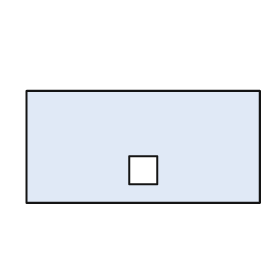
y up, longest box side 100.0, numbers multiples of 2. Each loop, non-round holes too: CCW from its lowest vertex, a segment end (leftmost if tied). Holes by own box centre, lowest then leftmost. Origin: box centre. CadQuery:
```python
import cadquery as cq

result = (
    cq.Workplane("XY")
    .moveTo(-50.0, -24.0)
    .lineTo(50.0, -24.0)
    .lineTo(50.0, 24.0)
    .lineTo(-50.0, 24.0)
    .close()
    .moveTo(-6.0, -16.0)
    .lineTo(6.0, -16.0)
    .lineTo(6.0, -4.0)
    .lineTo(-6.0, -4.0)
    .close()
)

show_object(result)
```